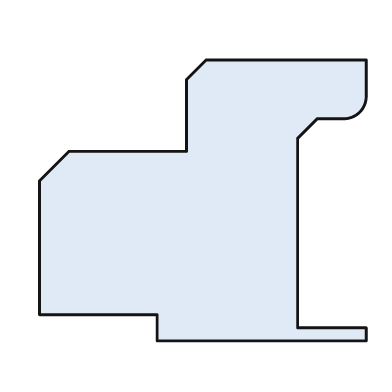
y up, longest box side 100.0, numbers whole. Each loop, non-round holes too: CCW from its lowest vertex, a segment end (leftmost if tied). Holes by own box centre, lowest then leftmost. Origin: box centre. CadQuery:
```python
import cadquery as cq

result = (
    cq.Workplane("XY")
    .moveTo(-14.0, -43.0)
    .lineTo(50.0, -43.0)
    .lineTo(50.0, -39.0)
    .lineTo(29.0, -39.0)
    .lineTo(29.0, 19.0)
    .lineTo(35.0, 25.0)
    .lineTo(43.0, 25.0)
    .threePointArc((48.0, 27.0), (50.0, 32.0))
    .lineTo(50.0, 43.0)
    .lineTo(1.0, 43.0)
    .lineTo(-5.0, 37.0)
    .lineTo(-5.0, 15.0)
    .lineTo(-41.0, 15.0)
    .lineTo(-50.0, 6.0)
    .lineTo(-50.0, -35.0)
    .lineTo(-14.0, -35.0)
    .close()
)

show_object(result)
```